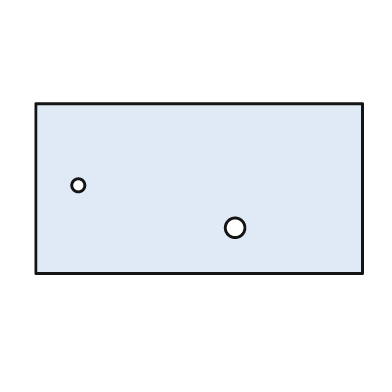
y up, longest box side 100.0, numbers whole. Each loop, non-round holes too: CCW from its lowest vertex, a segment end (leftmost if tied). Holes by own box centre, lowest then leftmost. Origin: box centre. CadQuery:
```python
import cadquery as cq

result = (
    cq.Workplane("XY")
    .moveTo(-50.0, -26.0)
    .lineTo(50.0, -26.0)
    .lineTo(50.0, 26.0)
    .lineTo(-50.0, 26.0)
    .close()
    .moveTo(11.0, -12.0)
    .circle(3.0)
    .moveTo(-37.0, 1.0)
    .circle(2.0)
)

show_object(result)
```